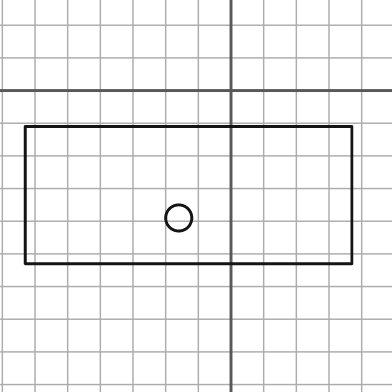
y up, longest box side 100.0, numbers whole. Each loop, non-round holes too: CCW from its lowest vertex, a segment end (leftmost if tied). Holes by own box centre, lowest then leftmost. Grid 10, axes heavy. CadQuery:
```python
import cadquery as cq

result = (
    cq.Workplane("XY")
    .moveTo(-63.0, -53.0)
    .lineTo(37.0, -53.0)
    .lineTo(37.0, -11.0)
    .lineTo(-63.0, -11.0)
    .close()
    .moveTo(-16.0, -39.0)
    .circle(4.0)
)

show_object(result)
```